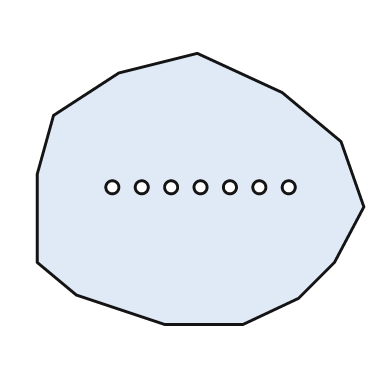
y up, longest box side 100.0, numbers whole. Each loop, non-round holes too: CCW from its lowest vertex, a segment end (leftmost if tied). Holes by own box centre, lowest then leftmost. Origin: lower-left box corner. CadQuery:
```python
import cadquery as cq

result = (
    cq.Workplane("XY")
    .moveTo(39.0, 0.0)
    .lineTo(63.0, 0.0)
    .lineTo(80.0, 8.0)
    .lineTo(91.0, 19.0)
    .lineTo(100.0, 36.0)
    .lineTo(93.0, 56.0)
    .lineTo(75.0, 71.0)
    .lineTo(49.0, 83.0)
    .lineTo(25.0, 77.0)
    .lineTo(5.0, 64.0)
    .lineTo(0.0, 46.0)
    .lineTo(0.0, 19.0)
    .lineTo(12.0, 9.0)
    .close()
    .moveTo(23.0, 42.0)
    .circle(2.0)
    .moveTo(32.0, 42.0)
    .circle(2.0)
    .moveTo(41.0, 42.0)
    .circle(2.0)
    .moveTo(50.0, 42.0)
    .circle(2.0)
    .moveTo(59.0, 42.0)
    .circle(2.0)
    .moveTo(68.0, 42.0)
    .circle(2.0)
    .moveTo(77.0, 42.0)
    .circle(2.0)
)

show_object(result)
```